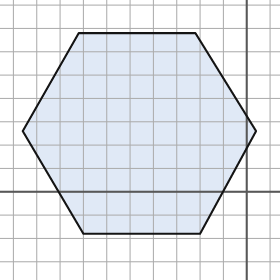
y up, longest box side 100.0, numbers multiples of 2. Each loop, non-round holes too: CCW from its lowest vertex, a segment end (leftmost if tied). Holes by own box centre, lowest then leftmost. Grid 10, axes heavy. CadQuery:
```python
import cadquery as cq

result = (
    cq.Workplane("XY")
    .moveTo(-70.0, -18.0)
    .lineTo(-20.0, -18.0)
    .lineTo(4.0, 26.0)
    .lineTo(-22.0, 68.0)
    .lineTo(-72.0, 68.0)
    .lineTo(-96.0, 26.0)
    .close()
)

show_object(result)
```